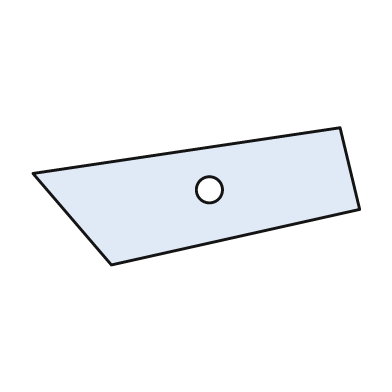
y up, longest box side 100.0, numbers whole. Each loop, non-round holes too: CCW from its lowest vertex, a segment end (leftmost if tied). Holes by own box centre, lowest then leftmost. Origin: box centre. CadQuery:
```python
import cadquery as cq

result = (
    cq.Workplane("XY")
    .moveTo(-26.0, -21.0)
    .lineTo(50.0, -4.0)
    .lineTo(44.0, 21.0)
    .lineTo(-50.0, 7.0)
    .close()
    .moveTo(4.0, 2.0)
    .circle(4.0)
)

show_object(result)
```